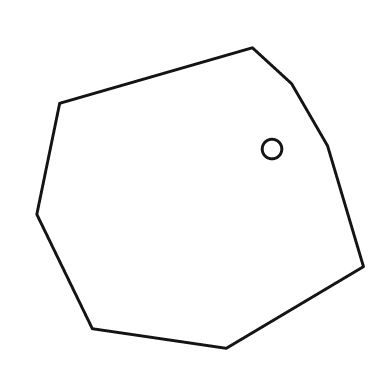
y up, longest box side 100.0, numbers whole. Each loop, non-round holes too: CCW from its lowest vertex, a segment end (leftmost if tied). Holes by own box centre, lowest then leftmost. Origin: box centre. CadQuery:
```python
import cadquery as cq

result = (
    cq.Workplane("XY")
    .moveTo(8.0, -46.0)
    .lineTo(50.0, -21.0)
    .lineTo(39.0, 16.0)
    .lineTo(28.0, 35.0)
    .lineTo(16.0, 46.0)
    .lineTo(-43.0, 29.0)
    .lineTo(-50.0, -5.0)
    .lineTo(-33.0, -40.0)
    .close()
    .moveTo(22.0, 15.0)
    .circle(3.0)
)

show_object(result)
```